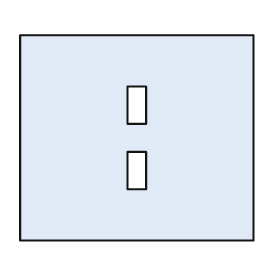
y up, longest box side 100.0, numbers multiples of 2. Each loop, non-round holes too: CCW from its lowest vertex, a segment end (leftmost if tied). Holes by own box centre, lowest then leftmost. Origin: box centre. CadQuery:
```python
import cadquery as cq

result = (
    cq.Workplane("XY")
    .moveTo(-50.0, -44.0)
    .lineTo(50.0, -44.0)
    .lineTo(50.0, 44.0)
    .lineTo(-50.0, 44.0)
    .close()
    .moveTo(-4.0, -22.0)
    .lineTo(4.0, -22.0)
    .lineTo(4.0, -6.0)
    .lineTo(-4.0, -6.0)
    .close()
    .moveTo(-4.0, 6.0)
    .lineTo(4.0, 6.0)
    .lineTo(4.0, 22.0)
    .lineTo(-4.0, 22.0)
    .close()
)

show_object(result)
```